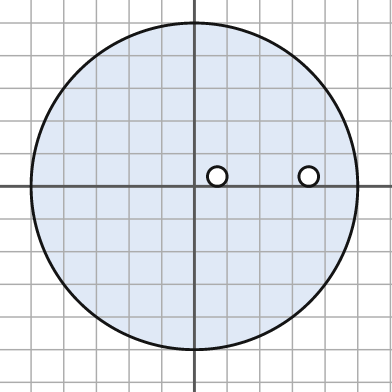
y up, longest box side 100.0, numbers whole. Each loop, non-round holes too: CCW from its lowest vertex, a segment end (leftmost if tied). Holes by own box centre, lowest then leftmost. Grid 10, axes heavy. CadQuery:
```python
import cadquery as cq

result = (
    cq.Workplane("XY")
    .moveTo(0.0, 0.0)
    .circle(50.0)
    .moveTo(7.0, 3.0)
    .circle(3.0)
    .moveTo(35.0, 3.0)
    .circle(3.0)
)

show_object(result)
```